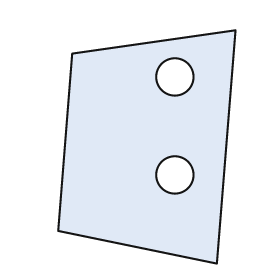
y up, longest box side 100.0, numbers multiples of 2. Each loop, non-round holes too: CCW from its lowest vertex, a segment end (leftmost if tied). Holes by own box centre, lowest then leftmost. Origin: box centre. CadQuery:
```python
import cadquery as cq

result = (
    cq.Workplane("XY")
    .moveTo(30.0, -50.0)
    .lineTo(38.0, 50.0)
    .lineTo(-32.0, 40.0)
    .lineTo(-38.0, -36.0)
    .close()
    .moveTo(12.0, -12.0)
    .circle(8.0)
    .moveTo(12.0, 30.0)
    .circle(8.0)
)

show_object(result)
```